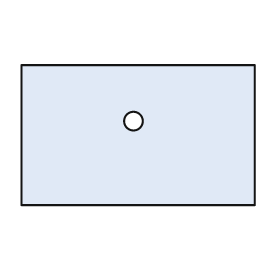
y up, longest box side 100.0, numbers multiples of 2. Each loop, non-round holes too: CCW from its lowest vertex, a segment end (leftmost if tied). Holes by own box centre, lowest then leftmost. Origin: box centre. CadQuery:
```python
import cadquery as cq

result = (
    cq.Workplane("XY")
    .moveTo(-50.0, -30.0)
    .lineTo(50.0, -30.0)
    .lineTo(50.0, 30.0)
    .lineTo(-50.0, 30.0)
    .close()
    .moveTo(-2.0, 6.0)
    .circle(4.0)
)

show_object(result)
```